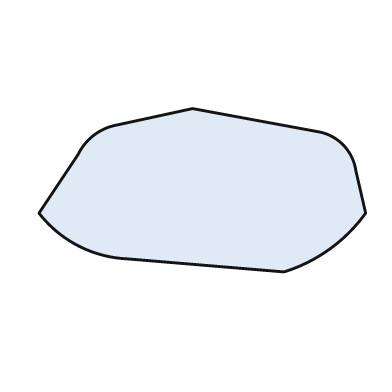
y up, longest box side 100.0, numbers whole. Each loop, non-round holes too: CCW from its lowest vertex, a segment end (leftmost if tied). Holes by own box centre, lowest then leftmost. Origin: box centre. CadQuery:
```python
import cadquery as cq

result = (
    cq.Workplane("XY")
    .moveTo(25.0, -25.0)
    .threePointArc((39.0, -18.0), (50.0, -7.0))
    .lineTo(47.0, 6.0)
    .threePointArc((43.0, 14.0), (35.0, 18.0))
    .lineTo(-3.0, 25.0)
    .lineTo(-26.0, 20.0)
    .threePointArc((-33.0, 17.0), (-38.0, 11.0))
    .lineTo(-50.0, -7.0)
    .threePointArc((-38.0, -17.0), (-23.0, -21.0))
    .close()
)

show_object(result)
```